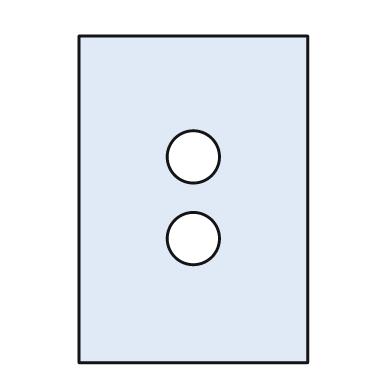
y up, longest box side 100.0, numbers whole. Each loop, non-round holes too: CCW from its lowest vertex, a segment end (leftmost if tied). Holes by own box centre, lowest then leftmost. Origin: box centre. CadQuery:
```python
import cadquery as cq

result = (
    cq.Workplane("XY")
    .moveTo(-35.0, -50.0)
    .lineTo(35.0, -50.0)
    .lineTo(35.0, 50.0)
    .lineTo(-35.0, 50.0)
    .close()
    .moveTo(0.0, -12.0)
    .circle(8.0)
    .moveTo(0.0, 13.0)
    .circle(8.0)
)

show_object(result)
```